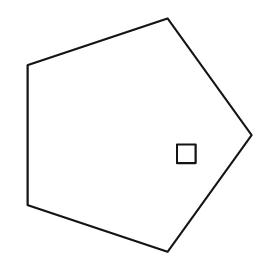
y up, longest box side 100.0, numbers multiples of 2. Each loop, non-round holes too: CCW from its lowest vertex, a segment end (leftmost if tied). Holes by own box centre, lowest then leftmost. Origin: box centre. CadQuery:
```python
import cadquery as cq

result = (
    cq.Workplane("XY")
    .moveTo(12.0, -50.0)
    .lineTo(48.0, 0.0)
    .lineTo(12.0, 50.0)
    .lineTo(-48.0, 30.0)
    .lineTo(-48.0, -30.0)
    .close()
    .moveTo(16.0, -12.0)
    .lineTo(24.0, -12.0)
    .lineTo(24.0, -4.0)
    .lineTo(16.0, -4.0)
    .close()
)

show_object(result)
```